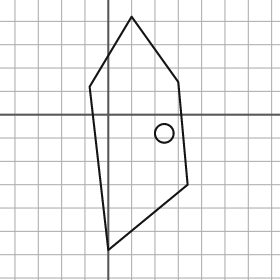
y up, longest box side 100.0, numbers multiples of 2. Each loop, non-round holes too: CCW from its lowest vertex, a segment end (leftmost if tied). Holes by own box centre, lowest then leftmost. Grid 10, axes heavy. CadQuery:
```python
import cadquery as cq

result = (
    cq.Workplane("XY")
    .moveTo(0.0, -58.0)
    .lineTo(34.0, -30.0)
    .lineTo(30.0, 14.0)
    .lineTo(10.0, 42.0)
    .lineTo(-8.0, 12.0)
    .close()
    .moveTo(24.0, -8.0)
    .circle(4.0)
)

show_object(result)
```